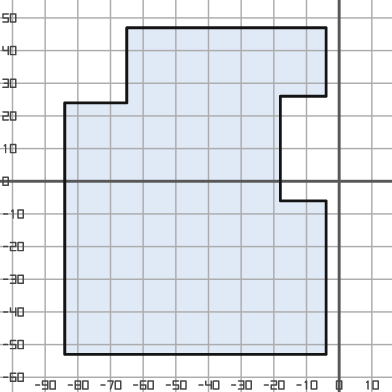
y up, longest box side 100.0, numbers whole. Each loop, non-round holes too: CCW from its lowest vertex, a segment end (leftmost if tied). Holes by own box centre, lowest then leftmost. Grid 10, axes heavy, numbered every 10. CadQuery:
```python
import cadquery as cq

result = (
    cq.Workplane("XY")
    .moveTo(-84.0, -53.0)
    .lineTo(-4.0, -53.0)
    .lineTo(-4.0, -6.0)
    .lineTo(-18.0, -6.0)
    .lineTo(-18.0, 26.0)
    .lineTo(-4.0, 26.0)
    .lineTo(-4.0, 47.0)
    .lineTo(-65.0, 47.0)
    .lineTo(-65.0, 24.0)
    .lineTo(-84.0, 24.0)
    .close()
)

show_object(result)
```